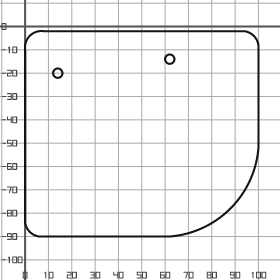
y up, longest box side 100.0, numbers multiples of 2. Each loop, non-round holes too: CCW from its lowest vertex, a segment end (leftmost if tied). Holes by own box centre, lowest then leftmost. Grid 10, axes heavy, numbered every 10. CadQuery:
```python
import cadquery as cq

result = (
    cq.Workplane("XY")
    .moveTo(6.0, -90.0)
    .lineTo(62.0, -90.0)
    .threePointArc((88.0, -78.0), (100.0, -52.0))
    .lineTo(100.0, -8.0)
    .threePointArc((98.0, -4.0), (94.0, -2.0))
    .lineTo(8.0, -2.0)
    .threePointArc((2.0, -4.0), (0.0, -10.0))
    .lineTo(0.0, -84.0)
    .threePointArc((2.0, -88.0), (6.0, -90.0))
    .close()
    .moveTo(14.0, -20.0)
    .circle(2.0)
    .moveTo(62.0, -14.0)
    .circle(2.0)
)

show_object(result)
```